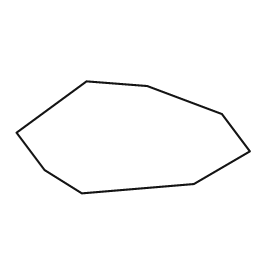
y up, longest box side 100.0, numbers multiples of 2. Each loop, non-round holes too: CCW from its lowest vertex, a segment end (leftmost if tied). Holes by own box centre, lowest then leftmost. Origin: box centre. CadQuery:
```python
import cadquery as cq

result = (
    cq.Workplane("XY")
    .moveTo(-22.0, -24.0)
    .lineTo(26.0, -20.0)
    .lineTo(50.0, -6.0)
    .lineTo(38.0, 10.0)
    .lineTo(6.0, 22.0)
    .lineTo(-20.0, 24.0)
    .lineTo(-50.0, 2.0)
    .lineTo(-38.0, -14.0)
    .close()
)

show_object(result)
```